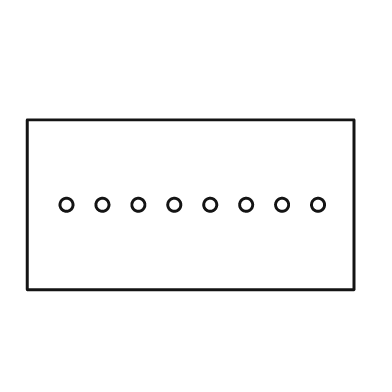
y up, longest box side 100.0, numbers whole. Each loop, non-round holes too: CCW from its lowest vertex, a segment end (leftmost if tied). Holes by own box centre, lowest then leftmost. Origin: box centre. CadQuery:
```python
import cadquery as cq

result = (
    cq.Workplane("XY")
    .moveTo(-50.0, -26.0)
    .lineTo(50.0, -26.0)
    .lineTo(50.0, 26.0)
    .lineTo(-50.0, 26.0)
    .close()
    .moveTo(-38.0, 0.0)
    .circle(2.0)
    .moveTo(-27.0, 0.0)
    .circle(2.0)
    .moveTo(-16.0, 0.0)
    .circle(2.0)
    .moveTo(-5.0, 0.0)
    .circle(2.0)
    .moveTo(6.0, 0.0)
    .circle(2.0)
    .moveTo(17.0, 0.0)
    .circle(2.0)
    .moveTo(28.0, 0.0)
    .circle(2.0)
    .moveTo(39.0, 0.0)
    .circle(2.0)
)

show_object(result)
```